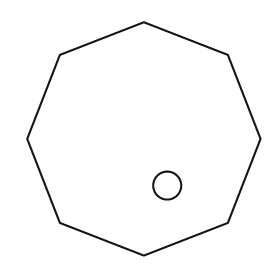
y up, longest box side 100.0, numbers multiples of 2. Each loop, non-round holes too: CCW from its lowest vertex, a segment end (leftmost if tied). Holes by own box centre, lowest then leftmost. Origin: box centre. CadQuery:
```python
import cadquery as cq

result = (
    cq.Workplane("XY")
    .moveTo(0.0, -50.0)
    .lineTo(36.0, -36.0)
    .lineTo(50.0, 0.0)
    .lineTo(36.0, 36.0)
    .lineTo(0.0, 50.0)
    .lineTo(-36.0, 36.0)
    .lineTo(-50.0, 0.0)
    .lineTo(-36.0, -36.0)
    .close()
    .moveTo(10.0, -20.0)
    .circle(6.0)
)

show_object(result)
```